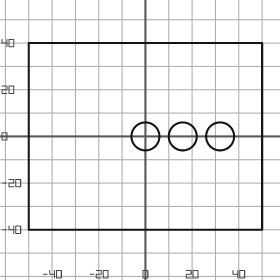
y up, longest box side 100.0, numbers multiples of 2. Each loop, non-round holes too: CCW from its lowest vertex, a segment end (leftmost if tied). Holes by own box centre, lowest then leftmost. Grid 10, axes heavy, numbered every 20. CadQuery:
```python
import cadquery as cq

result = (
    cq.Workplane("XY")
    .moveTo(-50.0, -40.0)
    .lineTo(50.0, -40.0)
    .lineTo(50.0, 40.0)
    .lineTo(-50.0, 40.0)
    .close()
    .moveTo(0.0, 0.0)
    .circle(6.0)
    .moveTo(16.0, 0.0)
    .circle(6.0)
    .moveTo(32.0, 0.0)
    .circle(6.0)
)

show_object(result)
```